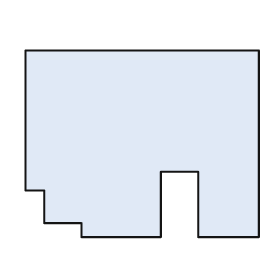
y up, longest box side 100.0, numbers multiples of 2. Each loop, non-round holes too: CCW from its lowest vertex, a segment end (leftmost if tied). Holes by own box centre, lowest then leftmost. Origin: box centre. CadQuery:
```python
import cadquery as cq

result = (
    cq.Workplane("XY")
    .moveTo(-26.0, -40.0)
    .lineTo(8.0, -40.0)
    .lineTo(8.0, -12.0)
    .lineTo(24.0, -12.0)
    .lineTo(24.0, -40.0)
    .lineTo(50.0, -40.0)
    .lineTo(50.0, 40.0)
    .lineTo(-50.0, 40.0)
    .lineTo(-50.0, -20.0)
    .lineTo(-42.0, -20.0)
    .lineTo(-42.0, -34.0)
    .lineTo(-26.0, -34.0)
    .close()
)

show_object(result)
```